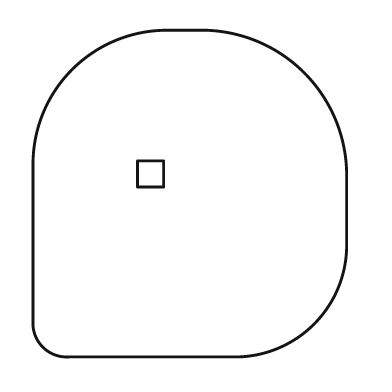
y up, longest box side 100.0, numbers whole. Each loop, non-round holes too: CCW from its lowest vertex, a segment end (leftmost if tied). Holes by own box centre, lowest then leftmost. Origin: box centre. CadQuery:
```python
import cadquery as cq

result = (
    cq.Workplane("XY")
    .moveTo(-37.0, -50.0)
    .lineTo(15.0, -50.0)
    .threePointArc((38.0, -40.0), (48.0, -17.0))
    .lineTo(48.0, 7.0)
    .threePointArc((35.0, 37.0), (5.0, 50.0))
    .lineTo(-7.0, 50.0)
    .threePointArc((-36.0, 38.0), (-48.0, 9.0))
    .lineTo(-48.0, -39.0)
    .threePointArc((-45.0, -47.0), (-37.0, -50.0))
    .close()
    .moveTo(-16.0, 2.0)
    .lineTo(-8.0, 2.0)
    .lineTo(-8.0, 10.0)
    .lineTo(-16.0, 10.0)
    .close()
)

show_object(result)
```